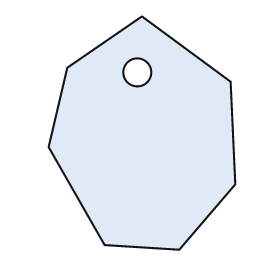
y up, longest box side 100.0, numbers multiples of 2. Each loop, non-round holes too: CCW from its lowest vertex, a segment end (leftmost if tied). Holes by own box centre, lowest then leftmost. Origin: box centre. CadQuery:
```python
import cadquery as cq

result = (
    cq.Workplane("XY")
    .moveTo(16.0, -50.0)
    .lineTo(40.0, -22.0)
    .lineTo(38.0, 22.0)
    .lineTo(0.0, 50.0)
    .lineTo(-32.0, 28.0)
    .lineTo(-40.0, -6.0)
    .lineTo(-16.0, -48.0)
    .close()
    .moveTo(-2.0, 26.0)
    .circle(6.0)
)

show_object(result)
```